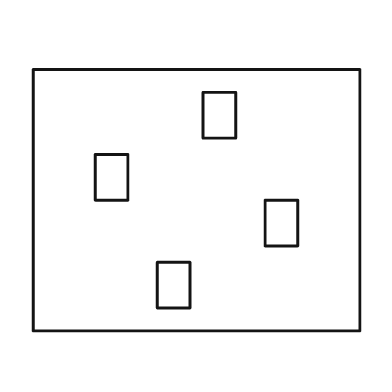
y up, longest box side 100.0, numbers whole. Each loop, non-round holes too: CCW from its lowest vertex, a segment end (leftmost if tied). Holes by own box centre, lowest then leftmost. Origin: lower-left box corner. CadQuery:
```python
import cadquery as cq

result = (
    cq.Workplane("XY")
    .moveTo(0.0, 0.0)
    .lineTo(100.0, 0.0)
    .lineTo(100.0, 80.0)
    .lineTo(0.0, 80.0)
    .close()
    .moveTo(38.0, 7.0)
    .lineTo(48.0, 7.0)
    .lineTo(48.0, 21.0)
    .lineTo(38.0, 21.0)
    .close()
    .moveTo(71.0, 26.0)
    .lineTo(81.0, 26.0)
    .lineTo(81.0, 40.0)
    .lineTo(71.0, 40.0)
    .close()
    .moveTo(19.0, 40.0)
    .lineTo(29.0, 40.0)
    .lineTo(29.0, 54.0)
    .lineTo(19.0, 54.0)
    .close()
    .moveTo(52.0, 59.0)
    .lineTo(62.0, 59.0)
    .lineTo(62.0, 73.0)
    .lineTo(52.0, 73.0)
    .close()
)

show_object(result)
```